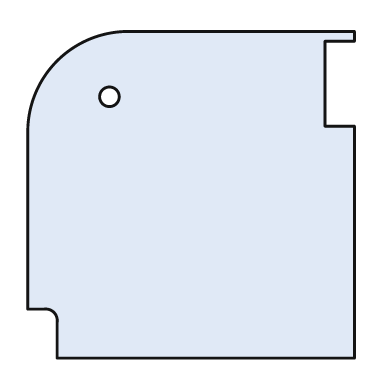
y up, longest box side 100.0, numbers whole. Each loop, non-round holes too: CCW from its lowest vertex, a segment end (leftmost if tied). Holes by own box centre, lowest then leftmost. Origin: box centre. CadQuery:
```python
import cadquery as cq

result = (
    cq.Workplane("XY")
    .moveTo(-41.0, -50.0)
    .lineTo(50.0, -50.0)
    .lineTo(50.0, 21.0)
    .lineTo(41.0, 21.0)
    .lineTo(41.0, 47.0)
    .lineTo(50.0, 47.0)
    .lineTo(50.0, 50.0)
    .lineTo(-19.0, 50.0)
    .threePointArc((-41.0, 41.0), (-50.0, 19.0))
    .lineTo(-50.0, -35.0)
    .lineTo(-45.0, -35.0)
    .threePointArc((-42.0, -36.0), (-41.0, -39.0))
    .close()
    .moveTo(-25.0, 30.0)
    .circle(3.0)
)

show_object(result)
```